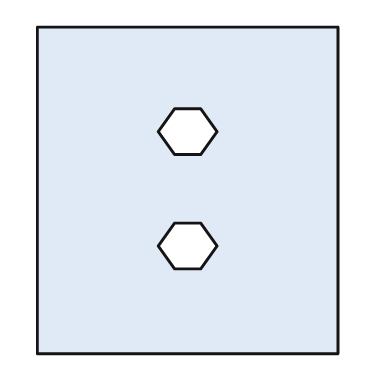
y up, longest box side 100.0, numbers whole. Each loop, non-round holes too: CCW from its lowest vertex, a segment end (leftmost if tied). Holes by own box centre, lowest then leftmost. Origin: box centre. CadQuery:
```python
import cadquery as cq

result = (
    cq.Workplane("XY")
    .moveTo(-46.0, -50.0)
    .lineTo(46.0, -50.0)
    .lineTo(46.0, 50.0)
    .lineTo(-46.0, 50.0)
    .close()
    .moveTo(-4.0, -24.0)
    .lineTo(4.0, -24.0)
    .lineTo(9.0, -17.0)
    .lineTo(4.0, -10.0)
    .lineTo(-4.0, -10.0)
    .lineTo(-9.0, -17.0)
    .close()
    .moveTo(-4.0, 11.0)
    .lineTo(4.0, 11.0)
    .lineTo(9.0, 18.0)
    .lineTo(4.0, 25.0)
    .lineTo(-4.0, 25.0)
    .lineTo(-9.0, 18.0)
    .close()
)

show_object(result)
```